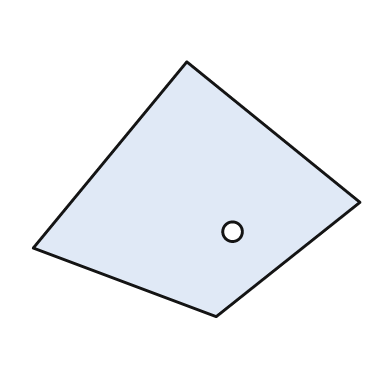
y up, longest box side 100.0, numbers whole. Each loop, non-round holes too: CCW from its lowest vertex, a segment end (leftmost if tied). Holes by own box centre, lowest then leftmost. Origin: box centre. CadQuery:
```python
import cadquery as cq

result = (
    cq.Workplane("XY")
    .moveTo(6.0, -39.0)
    .lineTo(50.0, -4.0)
    .lineTo(-3.0, 39.0)
    .lineTo(-50.0, -18.0)
    .close()
    .moveTo(11.0, -13.0)
    .circle(3.0)
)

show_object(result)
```